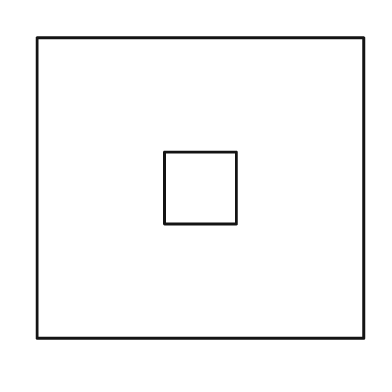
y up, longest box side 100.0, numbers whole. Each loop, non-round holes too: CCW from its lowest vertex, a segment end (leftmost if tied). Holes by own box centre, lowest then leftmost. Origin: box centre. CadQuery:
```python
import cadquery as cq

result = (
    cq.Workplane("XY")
    .moveTo(-50.0, -46.0)
    .lineTo(50.0, -46.0)
    .lineTo(50.0, 46.0)
    .lineTo(-50.0, 46.0)
    .close()
    .moveTo(-11.0, -11.0)
    .lineTo(11.0, -11.0)
    .lineTo(11.0, 11.0)
    .lineTo(-11.0, 11.0)
    .close()
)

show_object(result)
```